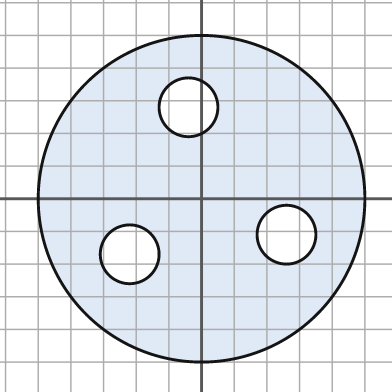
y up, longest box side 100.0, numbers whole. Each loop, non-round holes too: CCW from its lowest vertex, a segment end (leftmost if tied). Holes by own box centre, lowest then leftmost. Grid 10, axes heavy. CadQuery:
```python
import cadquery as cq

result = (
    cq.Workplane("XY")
    .moveTo(0.0, 0.0)
    .circle(50.0)
    .moveTo(-22.0, -17.0)
    .circle(9.0)
    .moveTo(26.0, -11.0)
    .circle(9.0)
    .moveTo(-4.0, 28.0)
    .circle(9.0)
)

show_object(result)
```